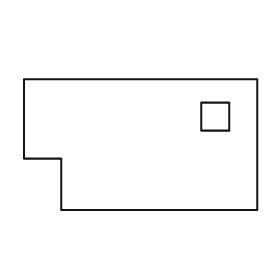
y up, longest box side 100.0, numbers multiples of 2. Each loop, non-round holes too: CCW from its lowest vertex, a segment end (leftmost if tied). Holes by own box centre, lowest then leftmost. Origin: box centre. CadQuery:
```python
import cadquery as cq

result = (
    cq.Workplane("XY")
    .moveTo(-34.0, -28.0)
    .lineTo(50.0, -28.0)
    .lineTo(50.0, 28.0)
    .lineTo(-50.0, 28.0)
    .lineTo(-50.0, -6.0)
    .lineTo(-34.0, -6.0)
    .close()
    .moveTo(26.0, 6.0)
    .lineTo(38.0, 6.0)
    .lineTo(38.0, 18.0)
    .lineTo(26.0, 18.0)
    .close()
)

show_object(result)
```